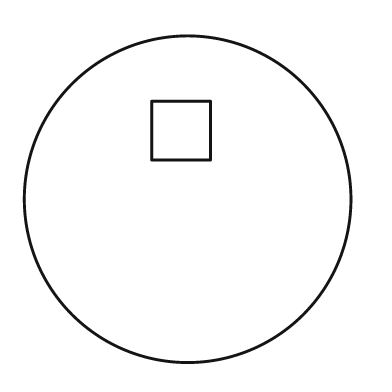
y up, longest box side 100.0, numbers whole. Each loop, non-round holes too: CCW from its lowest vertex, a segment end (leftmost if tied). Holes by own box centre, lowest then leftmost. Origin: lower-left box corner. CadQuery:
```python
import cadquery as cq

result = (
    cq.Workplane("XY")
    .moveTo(50.0, 50.0)
    .circle(50.0)
    .moveTo(39.0, 62.0)
    .lineTo(57.0, 62.0)
    .lineTo(57.0, 80.0)
    .lineTo(39.0, 80.0)
    .close()
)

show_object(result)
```